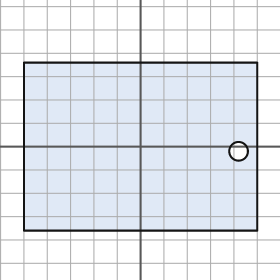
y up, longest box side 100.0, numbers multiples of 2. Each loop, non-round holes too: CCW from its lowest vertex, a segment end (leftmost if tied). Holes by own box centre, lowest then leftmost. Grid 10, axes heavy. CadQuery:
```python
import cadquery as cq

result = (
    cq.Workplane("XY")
    .moveTo(-50.0, -36.0)
    .lineTo(50.0, -36.0)
    .lineTo(50.0, 36.0)
    .lineTo(-50.0, 36.0)
    .close()
    .moveTo(42.0, -2.0)
    .circle(4.0)
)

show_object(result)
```